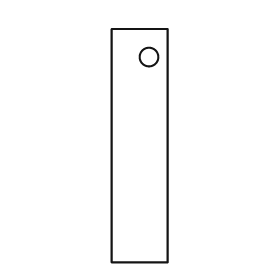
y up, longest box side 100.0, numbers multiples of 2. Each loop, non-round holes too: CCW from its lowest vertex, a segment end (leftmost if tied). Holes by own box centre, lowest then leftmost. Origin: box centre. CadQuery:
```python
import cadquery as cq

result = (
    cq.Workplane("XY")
    .moveTo(-12.0, -50.0)
    .lineTo(12.0, -50.0)
    .lineTo(12.0, 50.0)
    .lineTo(-12.0, 50.0)
    .close()
    .moveTo(4.0, 38.0)
    .circle(4.0)
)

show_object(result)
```